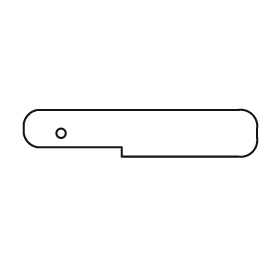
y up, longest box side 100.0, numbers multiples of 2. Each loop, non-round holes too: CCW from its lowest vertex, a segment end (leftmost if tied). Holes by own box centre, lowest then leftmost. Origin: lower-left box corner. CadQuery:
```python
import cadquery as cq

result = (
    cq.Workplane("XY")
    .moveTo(42.0, 0.0)
    .lineTo(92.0, 0.0)
    .threePointArc((98.0, 2.0), (100.0, 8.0))
    .lineTo(100.0, 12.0)
    .threePointArc((98.0, 18.0), (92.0, 20.0))
    .lineTo(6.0, 20.0)
    .threePointArc((2.0, 18.0), (0.0, 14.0))
    .lineTo(0.0, 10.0)
    .threePointArc((2.0, 6.0), (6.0, 4.0))
    .lineTo(42.0, 4.0)
    .close()
    .moveTo(16.0, 10.0)
    .circle(2.0)
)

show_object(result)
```